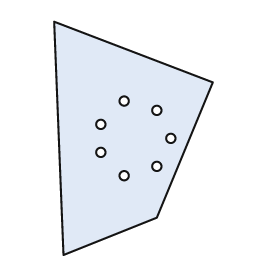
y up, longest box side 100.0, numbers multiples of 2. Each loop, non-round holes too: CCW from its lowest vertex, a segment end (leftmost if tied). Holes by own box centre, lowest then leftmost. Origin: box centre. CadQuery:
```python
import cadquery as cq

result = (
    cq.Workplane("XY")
    .moveTo(-30.0, -50.0)
    .lineTo(10.0, -34.0)
    .lineTo(34.0, 24.0)
    .lineTo(-34.0, 50.0)
    .close()
    .moveTo(-4.0, -16.0)
    .circle(2.0)
    .moveTo(10.0, -12.0)
    .circle(2.0)
    .moveTo(-14.0, -6.0)
    .circle(2.0)
    .moveTo(16.0, 0.0)
    .circle(2.0)
    .moveTo(-14.0, 6.0)
    .circle(2.0)
    .moveTo(10.0, 12.0)
    .circle(2.0)
    .moveTo(-4.0, 16.0)
    .circle(2.0)
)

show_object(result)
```